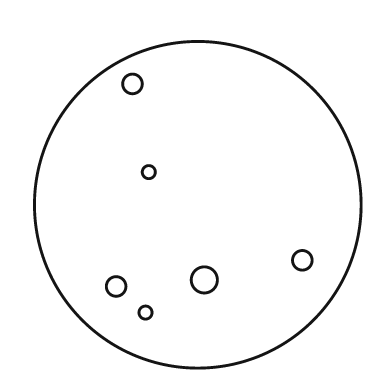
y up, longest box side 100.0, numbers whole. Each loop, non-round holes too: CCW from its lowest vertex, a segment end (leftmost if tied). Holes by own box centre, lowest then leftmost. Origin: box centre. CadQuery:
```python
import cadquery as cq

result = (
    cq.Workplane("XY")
    .moveTo(0.0, 0.0)
    .circle(50.0)
    .moveTo(-16.0, -33.0)
    .circle(2.0)
    .moveTo(-25.0, -25.0)
    .circle(3.0)
    .moveTo(2.0, -23.0)
    .circle(4.0)
    .moveTo(32.0, -17.0)
    .circle(3.0)
    .moveTo(-15.0, 10.0)
    .circle(2.0)
    .moveTo(-20.0, 37.0)
    .circle(3.0)
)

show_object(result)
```